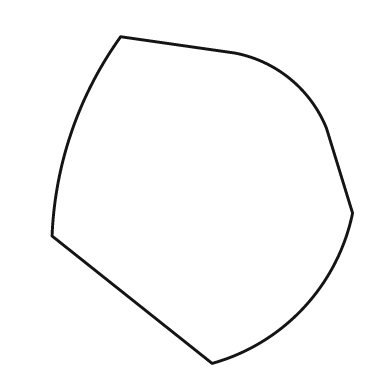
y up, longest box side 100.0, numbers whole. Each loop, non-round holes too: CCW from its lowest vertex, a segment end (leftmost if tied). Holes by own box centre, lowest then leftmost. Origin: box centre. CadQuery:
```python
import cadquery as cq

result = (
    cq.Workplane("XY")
    .moveTo(3.0, -50.0)
    .threePointArc((31.0, -33.0), (46.0, -4.0))
    .lineTo(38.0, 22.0)
    .threePointArc((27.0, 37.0), (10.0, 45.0))
    .lineTo(-25.0, 50.0)
    .threePointArc((-40.0, 21.0), (-46.0, -11.0))
    .close()
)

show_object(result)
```